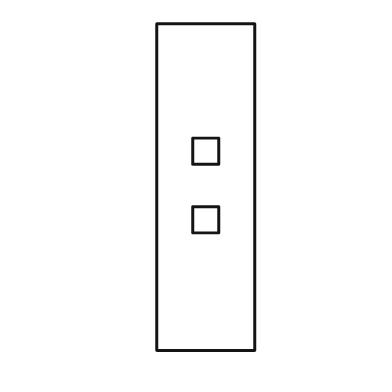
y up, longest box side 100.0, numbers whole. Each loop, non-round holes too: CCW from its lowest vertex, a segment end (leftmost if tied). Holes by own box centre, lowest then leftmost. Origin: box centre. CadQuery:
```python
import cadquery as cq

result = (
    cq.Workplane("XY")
    .moveTo(-15.0, -50.0)
    .lineTo(15.0, -50.0)
    .lineTo(15.0, 50.0)
    .lineTo(-15.0, 50.0)
    .close()
    .moveTo(-4.0, -14.0)
    .lineTo(4.0, -14.0)
    .lineTo(4.0, -6.0)
    .lineTo(-4.0, -6.0)
    .close()
    .moveTo(-4.0, 7.0)
    .lineTo(4.0, 7.0)
    .lineTo(4.0, 15.0)
    .lineTo(-4.0, 15.0)
    .close()
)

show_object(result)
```